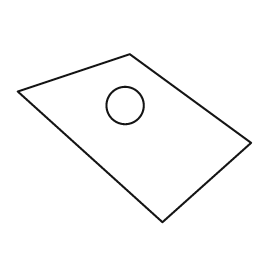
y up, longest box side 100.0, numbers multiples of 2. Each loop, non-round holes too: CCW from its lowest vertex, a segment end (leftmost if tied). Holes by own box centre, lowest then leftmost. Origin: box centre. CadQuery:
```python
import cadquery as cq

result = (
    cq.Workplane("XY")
    .moveTo(12.0, -36.0)
    .lineTo(50.0, -2.0)
    .lineTo(-2.0, 36.0)
    .lineTo(-50.0, 20.0)
    .close()
    .moveTo(-4.0, 14.0)
    .circle(8.0)
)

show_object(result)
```